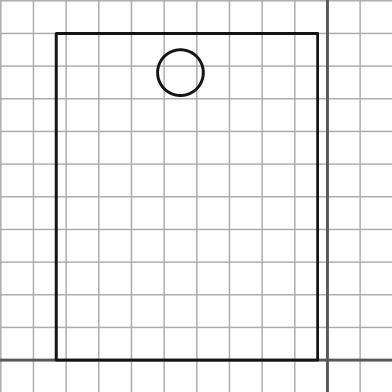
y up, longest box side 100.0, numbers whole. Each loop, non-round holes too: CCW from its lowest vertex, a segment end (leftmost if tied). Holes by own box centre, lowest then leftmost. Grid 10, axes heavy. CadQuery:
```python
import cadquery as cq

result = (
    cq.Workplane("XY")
    .moveTo(-83.0, 0.0)
    .lineTo(-3.0, 0.0)
    .lineTo(-3.0, 100.0)
    .lineTo(-83.0, 100.0)
    .close()
    .moveTo(-45.0, 88.0)
    .circle(7.0)
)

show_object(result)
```